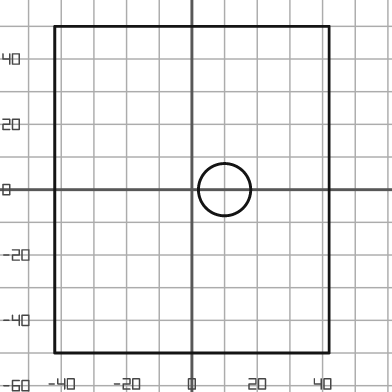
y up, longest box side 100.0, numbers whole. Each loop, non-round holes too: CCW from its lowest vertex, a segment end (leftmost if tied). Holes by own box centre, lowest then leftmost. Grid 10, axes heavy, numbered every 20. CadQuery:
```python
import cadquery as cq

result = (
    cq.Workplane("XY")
    .moveTo(-42.0, -50.0)
    .lineTo(42.0, -50.0)
    .lineTo(42.0, 50.0)
    .lineTo(-42.0, 50.0)
    .close()
    .moveTo(10.0, 0.0)
    .circle(8.0)
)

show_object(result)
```